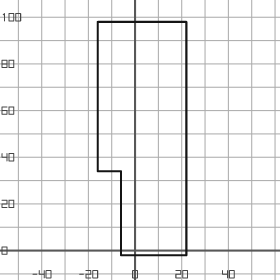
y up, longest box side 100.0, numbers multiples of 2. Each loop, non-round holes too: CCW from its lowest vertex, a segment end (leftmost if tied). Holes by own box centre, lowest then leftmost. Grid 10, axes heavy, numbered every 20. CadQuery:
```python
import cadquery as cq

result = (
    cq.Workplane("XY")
    .moveTo(-6.0, -2.0)
    .lineTo(22.0, -2.0)
    .lineTo(22.0, 98.0)
    .lineTo(-16.0, 98.0)
    .lineTo(-16.0, 34.0)
    .lineTo(-6.0, 34.0)
    .close()
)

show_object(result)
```